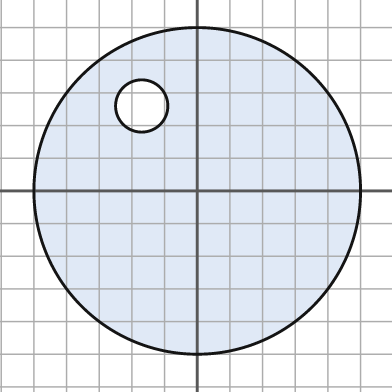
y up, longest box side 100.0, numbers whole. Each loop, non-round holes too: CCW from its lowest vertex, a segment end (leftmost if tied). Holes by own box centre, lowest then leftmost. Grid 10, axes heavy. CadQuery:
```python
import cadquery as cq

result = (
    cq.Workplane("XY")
    .moveTo(0.0, 0.0)
    .circle(50.0)
    .moveTo(-17.0, 26.0)
    .circle(8.0)
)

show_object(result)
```